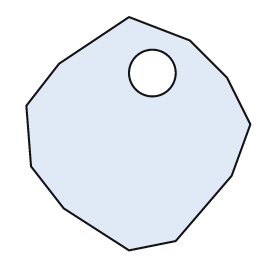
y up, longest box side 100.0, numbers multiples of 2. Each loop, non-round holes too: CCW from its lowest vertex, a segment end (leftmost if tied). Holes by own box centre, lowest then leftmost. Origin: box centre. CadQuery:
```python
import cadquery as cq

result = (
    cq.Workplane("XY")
    .moveTo(-4.0, -50.0)
    .lineTo(16.0, -46.0)
    .lineTo(40.0, -18.0)
    .lineTo(48.0, 4.0)
    .lineTo(38.0, 24.0)
    .lineTo(22.0, 40.0)
    .lineTo(-4.0, 50.0)
    .lineTo(-34.0, 30.0)
    .lineTo(-48.0, 12.0)
    .lineTo(-46.0, -14.0)
    .lineTo(-32.0, -32.0)
    .close()
    .moveTo(6.0, 26.0)
    .circle(10.0)
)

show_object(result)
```